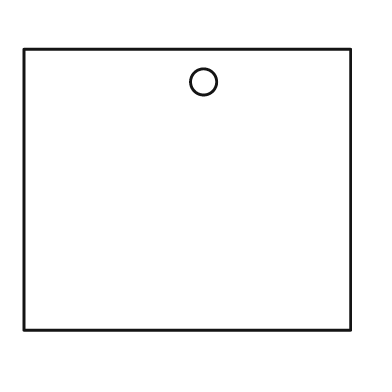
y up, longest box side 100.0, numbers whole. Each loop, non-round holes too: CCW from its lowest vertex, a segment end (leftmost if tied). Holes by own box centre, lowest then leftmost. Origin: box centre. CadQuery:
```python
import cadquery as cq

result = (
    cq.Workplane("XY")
    .moveTo(-50.0, -43.0)
    .lineTo(50.0, -43.0)
    .lineTo(50.0, 43.0)
    .lineTo(-50.0, 43.0)
    .close()
    .moveTo(5.0, 33.0)
    .circle(4.0)
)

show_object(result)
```